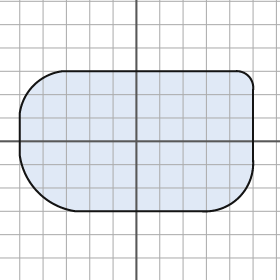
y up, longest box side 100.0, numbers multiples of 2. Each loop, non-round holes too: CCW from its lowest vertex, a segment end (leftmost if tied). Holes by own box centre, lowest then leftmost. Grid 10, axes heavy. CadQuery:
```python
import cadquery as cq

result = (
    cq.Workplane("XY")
    .moveTo(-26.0, -30.0)
    .lineTo(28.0, -30.0)
    .threePointArc((44.0, -24.0), (50.0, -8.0))
    .lineTo(50.0, 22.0)
    .threePointArc((48.0, 28.0), (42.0, 30.0))
    .lineTo(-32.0, 30.0)
    .threePointArc((-44.0, 24.0), (-50.0, 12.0))
    .lineTo(-50.0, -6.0)
    .threePointArc((-42.0, -22.0), (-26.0, -30.0))
    .close()
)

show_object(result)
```